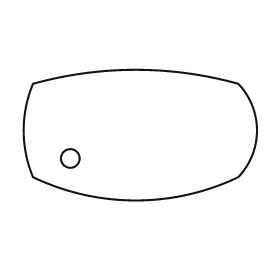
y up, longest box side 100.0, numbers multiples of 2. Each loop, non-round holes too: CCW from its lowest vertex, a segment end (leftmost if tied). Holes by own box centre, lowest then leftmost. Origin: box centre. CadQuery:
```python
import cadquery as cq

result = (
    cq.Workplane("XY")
    .moveTo(-46.0, -18.0)
    .threePointArc((-2.0, -28.0), (42.0, -18.0))
    .threePointArc((50.0, 2.0), (42.0, 22.0))
    .threePointArc((-2.0, 28.0), (-46.0, 22.0))
    .threePointArc((-50.0, 2.0), (-46.0, -18.0))
    .close()
    .moveTo(-30.0, -10.0)
    .circle(4.0)
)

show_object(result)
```